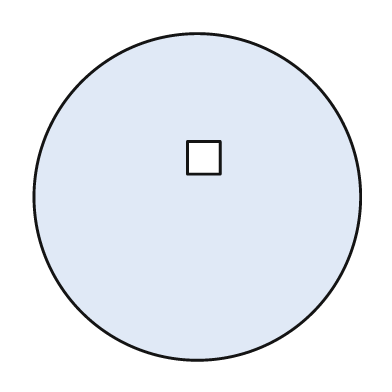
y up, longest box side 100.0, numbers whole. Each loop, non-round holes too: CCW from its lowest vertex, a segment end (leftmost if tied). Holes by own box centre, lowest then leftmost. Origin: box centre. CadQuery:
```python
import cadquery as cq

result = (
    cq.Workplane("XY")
    .moveTo(0.0, 0.0)
    .circle(50.0)
    .moveTo(-3.0, 7.0)
    .lineTo(7.0, 7.0)
    .lineTo(7.0, 17.0)
    .lineTo(-3.0, 17.0)
    .close()
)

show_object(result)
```